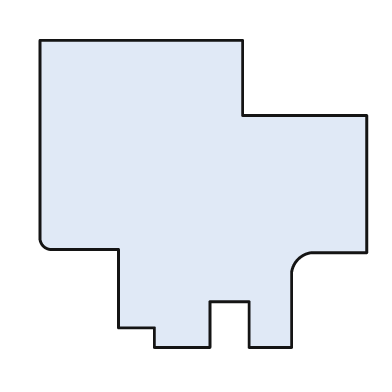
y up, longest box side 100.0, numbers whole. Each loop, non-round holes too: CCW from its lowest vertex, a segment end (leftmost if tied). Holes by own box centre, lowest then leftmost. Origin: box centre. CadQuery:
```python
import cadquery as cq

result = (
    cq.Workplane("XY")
    .moveTo(-15.0, -47.0)
    .lineTo(2.0, -47.0)
    .lineTo(2.0, -33.0)
    .lineTo(14.0, -33.0)
    .lineTo(14.0, -47.0)
    .lineTo(27.0, -47.0)
    .lineTo(27.0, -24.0)
    .threePointArc((29.0, -20.0), (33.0, -18.0))
    .lineTo(50.0, -18.0)
    .lineTo(50.0, 24.0)
    .lineTo(12.0, 24.0)
    .lineTo(12.0, 47.0)
    .lineTo(-50.0, 47.0)
    .lineTo(-50.0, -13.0)
    .threePointArc((-49.0, -16.0), (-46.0, -17.0))
    .lineTo(-26.0, -17.0)
    .lineTo(-26.0, -41.0)
    .lineTo(-15.0, -41.0)
    .close()
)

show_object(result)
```